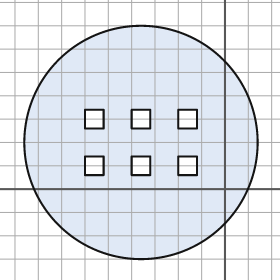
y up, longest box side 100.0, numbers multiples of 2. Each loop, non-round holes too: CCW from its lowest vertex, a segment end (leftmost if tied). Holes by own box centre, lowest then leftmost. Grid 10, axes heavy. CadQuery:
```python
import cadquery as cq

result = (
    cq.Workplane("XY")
    .moveTo(-36.0, 20.0)
    .circle(50.0)
    .moveTo(-60.0, 6.0)
    .lineTo(-52.0, 6.0)
    .lineTo(-52.0, 14.0)
    .lineTo(-60.0, 14.0)
    .close()
    .moveTo(-40.0, 6.0)
    .lineTo(-32.0, 6.0)
    .lineTo(-32.0, 14.0)
    .lineTo(-40.0, 14.0)
    .close()
    .moveTo(-20.0, 6.0)
    .lineTo(-12.0, 6.0)
    .lineTo(-12.0, 14.0)
    .lineTo(-20.0, 14.0)
    .close()
    .moveTo(-60.0, 26.0)
    .lineTo(-52.0, 26.0)
    .lineTo(-52.0, 34.0)
    .lineTo(-60.0, 34.0)
    .close()
    .moveTo(-40.0, 26.0)
    .lineTo(-32.0, 26.0)
    .lineTo(-32.0, 34.0)
    .lineTo(-40.0, 34.0)
    .close()
    .moveTo(-20.0, 26.0)
    .lineTo(-12.0, 26.0)
    .lineTo(-12.0, 34.0)
    .lineTo(-20.0, 34.0)
    .close()
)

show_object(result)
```